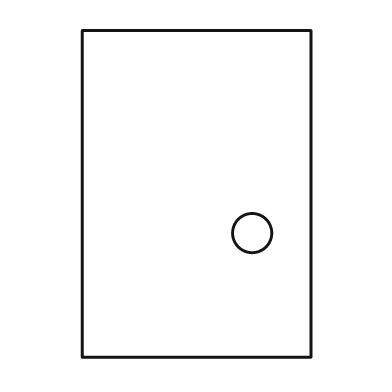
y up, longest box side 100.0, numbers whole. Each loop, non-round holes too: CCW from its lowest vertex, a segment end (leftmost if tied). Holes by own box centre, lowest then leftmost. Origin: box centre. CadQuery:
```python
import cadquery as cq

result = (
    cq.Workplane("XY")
    .moveTo(-35.0, -50.0)
    .lineTo(35.0, -50.0)
    .lineTo(35.0, 50.0)
    .lineTo(-35.0, 50.0)
    .close()
    .moveTo(17.0, -12.0)
    .circle(6.0)
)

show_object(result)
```